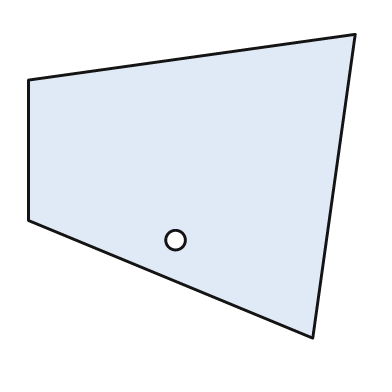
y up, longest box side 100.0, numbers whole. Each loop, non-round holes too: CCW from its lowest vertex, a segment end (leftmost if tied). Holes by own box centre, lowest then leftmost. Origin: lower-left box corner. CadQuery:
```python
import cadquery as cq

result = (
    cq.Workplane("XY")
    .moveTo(87.0, 0.0)
    .lineTo(100.0, 93.0)
    .lineTo(0.0, 79.0)
    .lineTo(0.0, 36.0)
    .close()
    .moveTo(45.0, 30.0)
    .circle(3.0)
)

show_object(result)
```